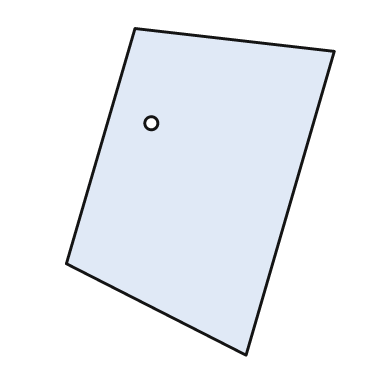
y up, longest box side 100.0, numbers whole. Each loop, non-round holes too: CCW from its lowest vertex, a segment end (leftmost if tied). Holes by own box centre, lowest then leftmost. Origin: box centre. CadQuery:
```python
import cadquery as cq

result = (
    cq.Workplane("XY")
    .moveTo(14.0, -50.0)
    .lineTo(41.0, 43.0)
    .lineTo(-20.0, 50.0)
    .lineTo(-41.0, -22.0)
    .close()
    .moveTo(-15.0, 21.0)
    .circle(2.0)
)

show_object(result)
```